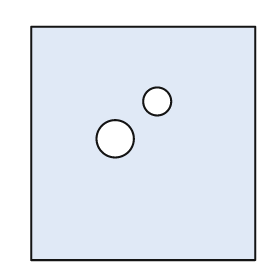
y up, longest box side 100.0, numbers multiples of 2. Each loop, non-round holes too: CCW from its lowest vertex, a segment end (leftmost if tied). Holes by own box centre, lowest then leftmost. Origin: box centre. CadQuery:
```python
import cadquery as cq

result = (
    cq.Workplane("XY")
    .moveTo(-48.0, -50.0)
    .lineTo(48.0, -50.0)
    .lineTo(48.0, 50.0)
    .lineTo(-48.0, 50.0)
    .close()
    .moveTo(-12.0, 2.0)
    .circle(8.0)
    .moveTo(6.0, 18.0)
    .circle(6.0)
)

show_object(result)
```